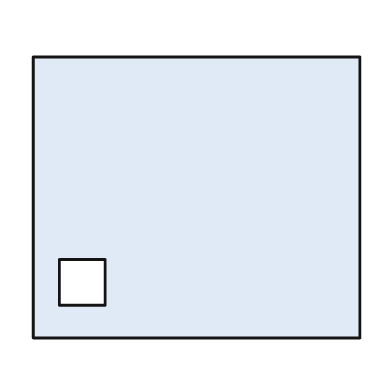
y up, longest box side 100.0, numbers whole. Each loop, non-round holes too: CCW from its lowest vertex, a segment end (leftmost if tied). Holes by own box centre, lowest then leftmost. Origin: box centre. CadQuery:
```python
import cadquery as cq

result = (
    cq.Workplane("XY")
    .moveTo(-50.0, -43.0)
    .lineTo(50.0, -43.0)
    .lineTo(50.0, 43.0)
    .lineTo(-50.0, 43.0)
    .close()
    .moveTo(-42.0, -33.0)
    .lineTo(-28.0, -33.0)
    .lineTo(-28.0, -19.0)
    .lineTo(-42.0, -19.0)
    .close()
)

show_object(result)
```